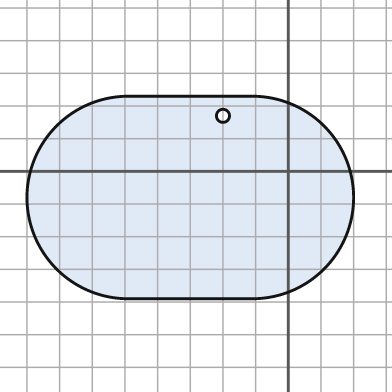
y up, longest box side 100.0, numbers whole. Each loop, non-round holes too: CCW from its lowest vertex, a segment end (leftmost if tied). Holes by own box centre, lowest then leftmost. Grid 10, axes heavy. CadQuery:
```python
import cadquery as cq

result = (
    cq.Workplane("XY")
    .moveTo(-49.0, -39.0)
    .lineTo(-11.0, -39.0)
    .threePointArc((20.0, -8.0), (-11.0, 23.0))
    .lineTo(-49.0, 23.0)
    .threePointArc((-80.0, -8.0), (-49.0, -39.0))
    .close()
    .moveTo(-20.0, 17.0)
    .circle(2.0)
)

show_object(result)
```